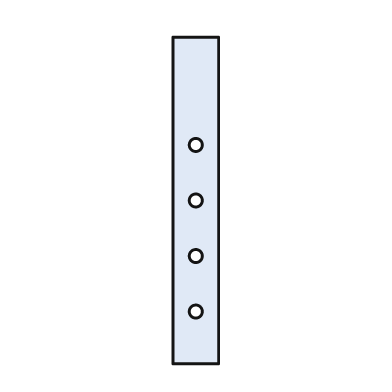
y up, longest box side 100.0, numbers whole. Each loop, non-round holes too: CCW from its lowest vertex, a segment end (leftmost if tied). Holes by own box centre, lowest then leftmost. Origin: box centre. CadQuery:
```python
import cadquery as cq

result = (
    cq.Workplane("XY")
    .moveTo(-7.0, -50.0)
    .lineTo(7.0, -50.0)
    .lineTo(7.0, 50.0)
    .lineTo(-7.0, 50.0)
    .close()
    .moveTo(0.0, -34.0)
    .circle(2.0)
    .moveTo(0.0, -17.0)
    .circle(2.0)
    .moveTo(0.0, 0.0)
    .circle(2.0)
    .moveTo(0.0, 17.0)
    .circle(2.0)
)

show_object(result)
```